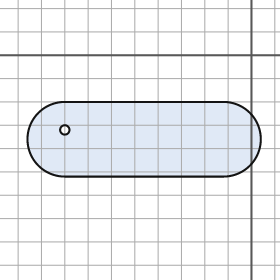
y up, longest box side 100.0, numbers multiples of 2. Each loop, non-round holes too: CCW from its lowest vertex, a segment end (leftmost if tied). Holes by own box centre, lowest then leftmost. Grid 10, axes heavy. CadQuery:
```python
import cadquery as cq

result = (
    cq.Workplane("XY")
    .moveTo(-80.0, -52.0)
    .lineTo(-12.0, -52.0)
    .threePointArc((4.0, -36.0), (-12.0, -20.0))
    .lineTo(-80.0, -20.0)
    .threePointArc((-96.0, -36.0), (-80.0, -52.0))
    .close()
    .moveTo(-80.0, -32.0)
    .circle(2.0)
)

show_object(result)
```